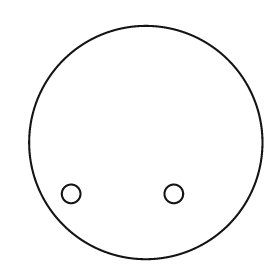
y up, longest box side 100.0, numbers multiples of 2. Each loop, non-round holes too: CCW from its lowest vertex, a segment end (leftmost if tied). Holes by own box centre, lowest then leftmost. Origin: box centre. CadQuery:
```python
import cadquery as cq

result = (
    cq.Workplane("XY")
    .moveTo(0.0, 0.0)
    .circle(50.0)
    .moveTo(-32.0, -22.0)
    .circle(4.0)
    .moveTo(12.0, -22.0)
    .circle(4.0)
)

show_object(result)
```